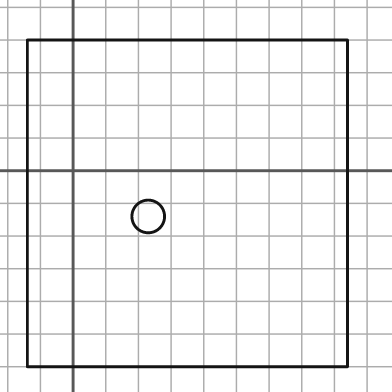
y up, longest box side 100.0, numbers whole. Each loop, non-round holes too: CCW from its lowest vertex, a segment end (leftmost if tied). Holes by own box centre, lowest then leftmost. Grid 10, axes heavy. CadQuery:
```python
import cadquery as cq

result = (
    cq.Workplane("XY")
    .moveTo(-14.0, -60.0)
    .lineTo(84.0, -60.0)
    .lineTo(84.0, 40.0)
    .lineTo(-14.0, 40.0)
    .close()
    .moveTo(23.0, -14.0)
    .circle(5.0)
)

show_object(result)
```